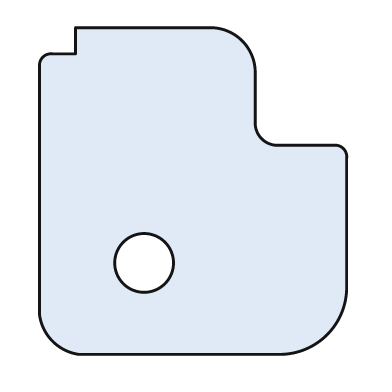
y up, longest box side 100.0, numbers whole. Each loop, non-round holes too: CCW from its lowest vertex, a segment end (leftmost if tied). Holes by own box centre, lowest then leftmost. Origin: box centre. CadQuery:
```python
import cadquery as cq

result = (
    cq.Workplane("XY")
    .moveTo(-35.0, -50.0)
    .lineTo(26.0, -50.0)
    .threePointArc((41.0, -44.0), (47.0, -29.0))
    .lineTo(47.0, 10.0)
    .threePointArc((46.0, 13.0), (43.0, 14.0))
    .lineTo(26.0, 14.0)
    .threePointArc((21.0, 16.0), (19.0, 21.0))
    .lineTo(19.0, 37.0)
    .threePointArc((15.0, 46.0), (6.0, 50.0))
    .lineTo(-36.0, 50.0)
    .lineTo(-36.0, 42.0)
    .lineTo(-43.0, 42.0)
    .threePointArc((-46.0, 41.0), (-47.0, 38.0))
    .lineTo(-47.0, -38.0)
    .threePointArc((-43.0, -46.0), (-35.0, -50.0))
    .close()
    .moveTo(-15.0, -22.0)
    .circle(9.0)
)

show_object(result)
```